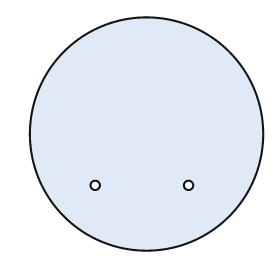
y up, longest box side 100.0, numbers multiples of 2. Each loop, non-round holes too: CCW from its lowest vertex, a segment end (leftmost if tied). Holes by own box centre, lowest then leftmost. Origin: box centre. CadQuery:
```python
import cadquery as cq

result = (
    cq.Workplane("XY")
    .moveTo(0.0, 0.0)
    .circle(50.0)
    .moveTo(-22.0, -22.0)
    .circle(2.0)
    .moveTo(18.0, -22.0)
    .circle(2.0)
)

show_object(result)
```